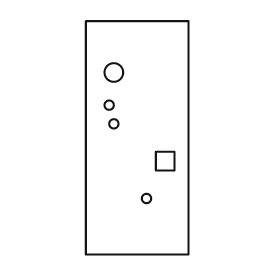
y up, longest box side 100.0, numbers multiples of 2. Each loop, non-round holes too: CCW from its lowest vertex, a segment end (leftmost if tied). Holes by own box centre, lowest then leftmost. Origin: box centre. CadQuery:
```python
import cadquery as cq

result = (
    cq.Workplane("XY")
    .moveTo(-22.0, -50.0)
    .lineTo(22.0, -50.0)
    .lineTo(22.0, 50.0)
    .lineTo(-22.0, 50.0)
    .close()
    .moveTo(4.0, -26.0)
    .circle(2.0)
    .moveTo(8.0, -14.0)
    .lineTo(16.0, -14.0)
    .lineTo(16.0, -6.0)
    .lineTo(8.0, -6.0)
    .close()
    .moveTo(-10.0, 6.0)
    .circle(2.0)
    .moveTo(-12.0, 14.0)
    .circle(2.0)
    .moveTo(-10.0, 28.0)
    .circle(4.0)
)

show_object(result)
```